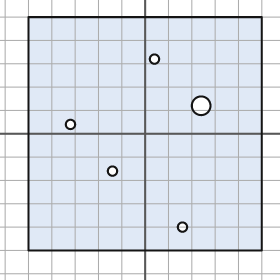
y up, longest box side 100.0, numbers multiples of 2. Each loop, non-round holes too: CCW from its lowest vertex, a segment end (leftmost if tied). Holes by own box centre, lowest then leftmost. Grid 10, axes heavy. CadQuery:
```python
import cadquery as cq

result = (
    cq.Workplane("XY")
    .moveTo(-50.0, -50.0)
    .lineTo(50.0, -50.0)
    .lineTo(50.0, 50.0)
    .lineTo(-50.0, 50.0)
    .close()
    .moveTo(16.0, -40.0)
    .circle(2.0)
    .moveTo(-14.0, -16.0)
    .circle(2.0)
    .moveTo(-32.0, 4.0)
    .circle(2.0)
    .moveTo(24.0, 12.0)
    .circle(4.0)
    .moveTo(4.0, 32.0)
    .circle(2.0)
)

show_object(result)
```